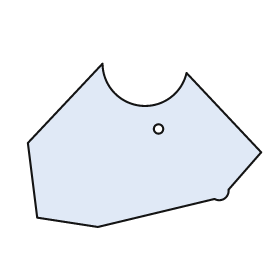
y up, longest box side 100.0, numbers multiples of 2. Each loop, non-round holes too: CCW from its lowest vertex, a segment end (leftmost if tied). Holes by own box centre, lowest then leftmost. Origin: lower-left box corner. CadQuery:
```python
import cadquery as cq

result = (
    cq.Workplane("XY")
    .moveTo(30.0, 0.0)
    .lineTo(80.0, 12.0)
    .threePointArc((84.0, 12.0), (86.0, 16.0))
    .lineTo(100.0, 32.0)
    .lineTo(68.0, 66.0)
    .threePointArc((48.0, 52.0), (32.0, 70.0))
    .lineTo(0.0, 36.0)
    .lineTo(4.0, 4.0)
    .close()
    .moveTo(56.0, 42.0)
    .circle(2.0)
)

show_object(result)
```